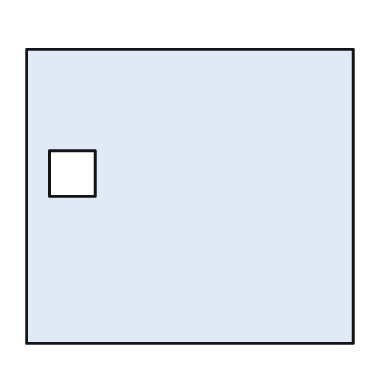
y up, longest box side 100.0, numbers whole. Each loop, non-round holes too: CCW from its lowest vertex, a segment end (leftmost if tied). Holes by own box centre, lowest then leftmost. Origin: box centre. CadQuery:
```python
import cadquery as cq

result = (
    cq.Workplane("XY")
    .moveTo(-50.0, -45.0)
    .lineTo(50.0, -45.0)
    .lineTo(50.0, 45.0)
    .lineTo(-50.0, 45.0)
    .close()
    .moveTo(-43.0, 0.0)
    .lineTo(-29.0, 0.0)
    .lineTo(-29.0, 14.0)
    .lineTo(-43.0, 14.0)
    .close()
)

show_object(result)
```